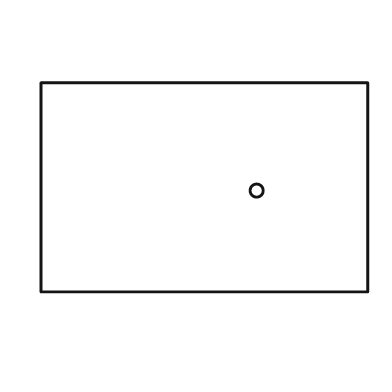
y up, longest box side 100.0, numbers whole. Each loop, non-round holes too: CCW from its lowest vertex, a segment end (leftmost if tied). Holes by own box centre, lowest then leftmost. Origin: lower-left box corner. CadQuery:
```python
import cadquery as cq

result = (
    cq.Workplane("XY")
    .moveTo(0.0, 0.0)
    .lineTo(100.0, 0.0)
    .lineTo(100.0, 64.0)
    .lineTo(0.0, 64.0)
    .close()
    .moveTo(66.0, 31.0)
    .circle(2.0)
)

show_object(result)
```